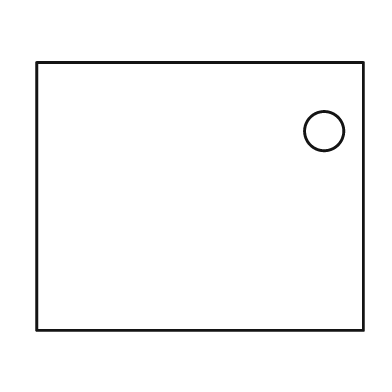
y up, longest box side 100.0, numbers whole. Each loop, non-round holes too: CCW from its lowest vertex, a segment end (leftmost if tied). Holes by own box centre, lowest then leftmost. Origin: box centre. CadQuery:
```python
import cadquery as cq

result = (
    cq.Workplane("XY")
    .moveTo(-50.0, -41.0)
    .lineTo(50.0, -41.0)
    .lineTo(50.0, 41.0)
    .lineTo(-50.0, 41.0)
    .close()
    .moveTo(38.0, 20.0)
    .circle(6.0)
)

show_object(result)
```